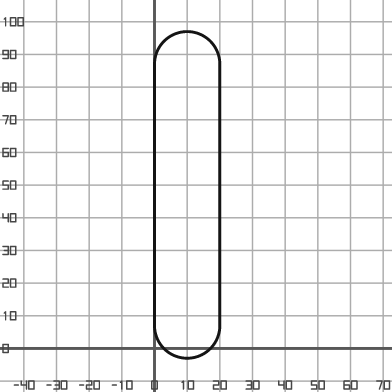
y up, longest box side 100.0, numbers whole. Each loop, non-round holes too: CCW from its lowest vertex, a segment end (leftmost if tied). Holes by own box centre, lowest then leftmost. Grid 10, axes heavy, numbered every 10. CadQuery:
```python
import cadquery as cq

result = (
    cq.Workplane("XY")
    .moveTo(0.0, 7.0)
    .threePointArc((10.0, -3.0), (20.0, 7.0))
    .lineTo(20.0, 87.0)
    .threePointArc((10.0, 97.0), (0.0, 87.0))
    .close()
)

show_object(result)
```